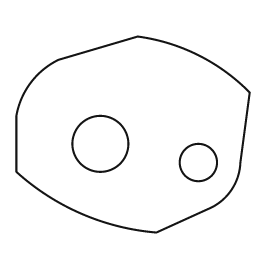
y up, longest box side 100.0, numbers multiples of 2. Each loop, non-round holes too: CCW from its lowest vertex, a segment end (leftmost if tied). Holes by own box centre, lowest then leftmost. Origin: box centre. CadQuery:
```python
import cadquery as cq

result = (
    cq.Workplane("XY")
    .moveTo(10.0, -42.0)
    .lineTo(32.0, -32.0)
    .threePointArc((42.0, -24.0), (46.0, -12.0))
    .lineTo(50.0, 18.0)
    .threePointArc((28.0, 34.0), (2.0, 42.0))
    .lineTo(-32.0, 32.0)
    .threePointArc((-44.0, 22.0), (-50.0, 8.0))
    .lineTo(-50.0, -16.0)
    .threePointArc((-22.0, -34.0), (10.0, -42.0))
    .close()
    .moveTo(28.0, -12.0)
    .circle(8.0)
    .moveTo(-14.0, -4.0)
    .circle(12.0)
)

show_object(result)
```